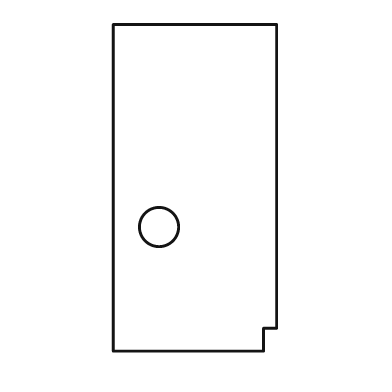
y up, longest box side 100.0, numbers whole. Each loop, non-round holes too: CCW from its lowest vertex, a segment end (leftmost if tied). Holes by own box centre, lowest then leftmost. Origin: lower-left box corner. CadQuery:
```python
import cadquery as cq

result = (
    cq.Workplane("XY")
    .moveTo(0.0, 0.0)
    .lineTo(46.0, 0.0)
    .lineTo(46.0, 7.0)
    .lineTo(50.0, 7.0)
    .lineTo(50.0, 100.0)
    .lineTo(0.0, 100.0)
    .close()
    .moveTo(14.0, 38.0)
    .circle(6.0)
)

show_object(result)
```